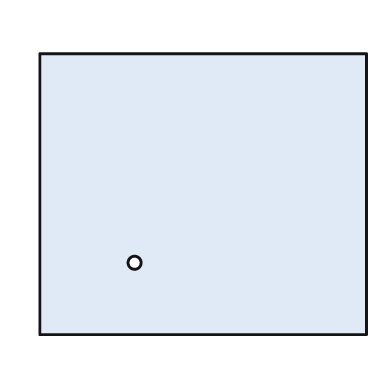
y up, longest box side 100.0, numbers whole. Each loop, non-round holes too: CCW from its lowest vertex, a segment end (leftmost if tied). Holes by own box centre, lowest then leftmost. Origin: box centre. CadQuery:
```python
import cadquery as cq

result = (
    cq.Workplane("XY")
    .moveTo(-50.0, -43.0)
    .lineTo(50.0, -43.0)
    .lineTo(50.0, 43.0)
    .lineTo(-50.0, 43.0)
    .close()
    .moveTo(-21.0, -21.0)
    .circle(2.0)
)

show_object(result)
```